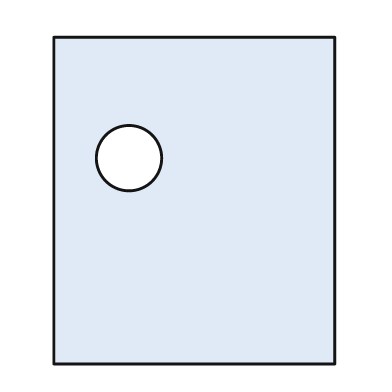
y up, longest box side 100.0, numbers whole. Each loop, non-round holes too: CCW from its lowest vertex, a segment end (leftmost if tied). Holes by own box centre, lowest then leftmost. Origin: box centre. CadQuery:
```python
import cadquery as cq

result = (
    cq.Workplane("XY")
    .moveTo(-43.0, -50.0)
    .lineTo(43.0, -50.0)
    .lineTo(43.0, 50.0)
    .lineTo(-43.0, 50.0)
    .close()
    .moveTo(-20.0, 13.0)
    .circle(10.0)
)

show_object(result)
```